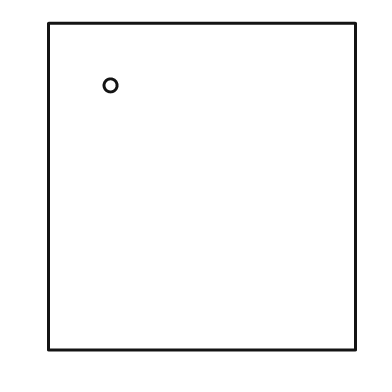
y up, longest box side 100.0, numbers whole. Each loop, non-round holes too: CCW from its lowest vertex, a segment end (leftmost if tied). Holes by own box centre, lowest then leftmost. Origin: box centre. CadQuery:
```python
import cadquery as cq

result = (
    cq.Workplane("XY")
    .moveTo(-47.0, -50.0)
    .lineTo(47.0, -50.0)
    .lineTo(47.0, 50.0)
    .lineTo(-47.0, 50.0)
    .close()
    .moveTo(-28.0, 31.0)
    .circle(2.0)
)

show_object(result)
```